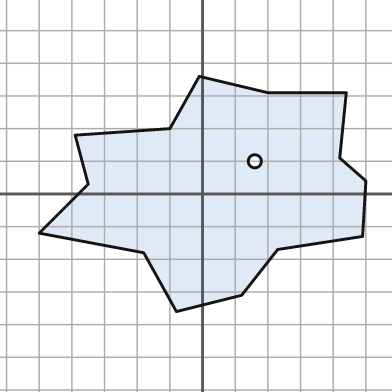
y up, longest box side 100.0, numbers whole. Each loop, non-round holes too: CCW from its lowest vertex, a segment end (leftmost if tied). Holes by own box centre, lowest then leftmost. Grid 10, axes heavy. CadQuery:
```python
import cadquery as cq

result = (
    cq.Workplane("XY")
    .moveTo(-8.0, -36.0)
    .lineTo(12.0, -31.0)
    .lineTo(23.0, -17.0)
    .lineTo(49.0, -13.0)
    .lineTo(50.0, 4.0)
    .lineTo(42.0, 11.0)
    .lineTo(44.0, 31.0)
    .lineTo(20.0, 31.0)
    .lineTo(-1.0, 36.0)
    .lineTo(-10.0, 20.0)
    .lineTo(-39.0, 18.0)
    .lineTo(-35.0, 3.0)
    .lineTo(-50.0, -12.0)
    .lineTo(-18.0, -18.0)
    .close()
    .moveTo(16.0, 10.0)
    .circle(2.0)
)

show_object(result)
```